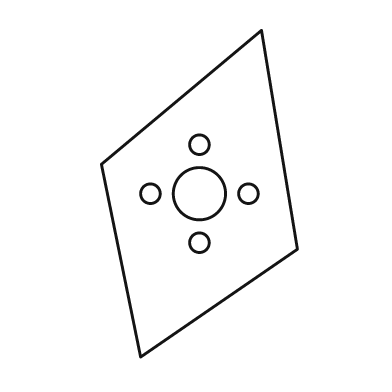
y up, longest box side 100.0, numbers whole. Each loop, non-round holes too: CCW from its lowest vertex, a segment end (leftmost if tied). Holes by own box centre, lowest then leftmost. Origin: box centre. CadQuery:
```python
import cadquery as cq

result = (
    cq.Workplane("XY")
    .moveTo(-18.0, -50.0)
    .lineTo(30.0, -17.0)
    .lineTo(19.0, 50.0)
    .lineTo(-30.0, 9.0)
    .close()
    .moveTo(0.0, -15.0)
    .circle(3.0)
    .moveTo(-15.0, 0.0)
    .circle(3.0)
    .moveTo(0.0, 0.0)
    .circle(8.0)
    .moveTo(15.0, 0.0)
    .circle(3.0)
    .moveTo(0.0, 15.0)
    .circle(3.0)
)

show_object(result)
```